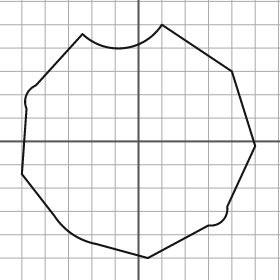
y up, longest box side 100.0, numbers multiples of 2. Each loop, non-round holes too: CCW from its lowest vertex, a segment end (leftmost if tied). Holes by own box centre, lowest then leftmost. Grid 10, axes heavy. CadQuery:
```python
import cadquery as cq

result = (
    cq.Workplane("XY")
    .moveTo(4.0, -50.0)
    .lineTo(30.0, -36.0)
    .threePointArc((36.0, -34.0), (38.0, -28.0))
    .lineTo(50.0, -2.0)
    .lineTo(40.0, 30.0)
    .lineTo(10.0, 50.0)
    .threePointArc((-6.0, 40.0), (-24.0, 46.0))
    .lineTo(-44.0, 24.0)
    .threePointArc((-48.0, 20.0), (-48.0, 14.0))
    .lineTo(-50.0, -14.0)
    .lineTo(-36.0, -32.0)
    .threePointArc((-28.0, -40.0), (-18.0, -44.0))
    .close()
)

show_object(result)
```